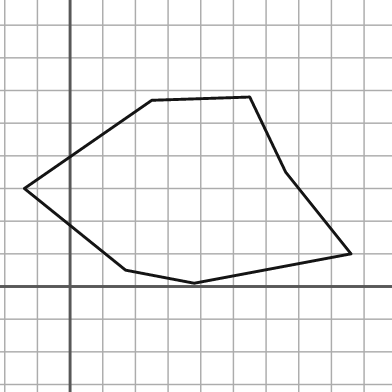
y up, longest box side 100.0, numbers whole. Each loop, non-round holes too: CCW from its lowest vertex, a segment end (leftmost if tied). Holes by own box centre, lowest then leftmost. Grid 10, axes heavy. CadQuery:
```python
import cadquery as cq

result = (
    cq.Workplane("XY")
    .moveTo(38.0, 1.0)
    .lineTo(86.0, 10.0)
    .lineTo(66.0, 35.0)
    .lineTo(55.0, 58.0)
    .lineTo(25.0, 57.0)
    .lineTo(-14.0, 30.0)
    .lineTo(17.0, 5.0)
    .close()
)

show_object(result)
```